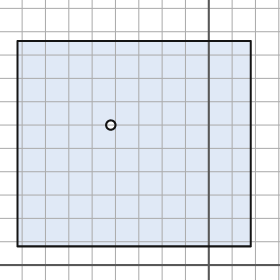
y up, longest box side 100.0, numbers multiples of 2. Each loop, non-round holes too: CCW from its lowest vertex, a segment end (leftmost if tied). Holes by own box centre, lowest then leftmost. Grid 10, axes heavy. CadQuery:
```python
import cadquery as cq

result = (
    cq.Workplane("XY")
    .moveTo(-82.0, 8.0)
    .lineTo(18.0, 8.0)
    .lineTo(18.0, 96.0)
    .lineTo(-82.0, 96.0)
    .close()
    .moveTo(-42.0, 60.0)
    .circle(2.0)
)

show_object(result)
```